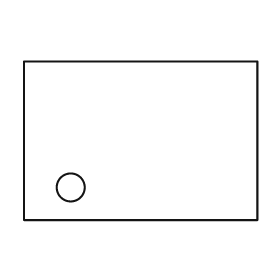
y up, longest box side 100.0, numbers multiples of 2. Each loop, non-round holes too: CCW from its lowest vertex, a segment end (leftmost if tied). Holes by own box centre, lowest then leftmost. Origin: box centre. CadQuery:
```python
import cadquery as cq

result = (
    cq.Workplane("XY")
    .moveTo(-50.0, -34.0)
    .lineTo(50.0, -34.0)
    .lineTo(50.0, 34.0)
    .lineTo(-50.0, 34.0)
    .close()
    .moveTo(-30.0, -20.0)
    .circle(6.0)
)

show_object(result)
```